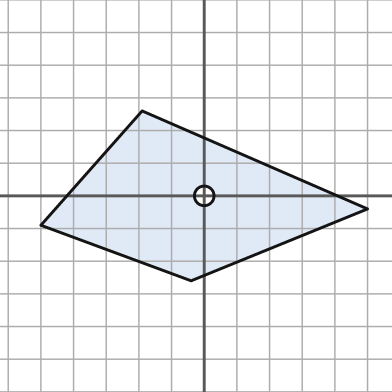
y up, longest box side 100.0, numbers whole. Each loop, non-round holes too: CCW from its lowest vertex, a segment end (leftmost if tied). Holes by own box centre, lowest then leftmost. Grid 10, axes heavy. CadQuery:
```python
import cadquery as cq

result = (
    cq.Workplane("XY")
    .moveTo(-4.0, -26.0)
    .lineTo(50.0, -4.0)
    .lineTo(-19.0, 26.0)
    .lineTo(-50.0, -9.0)
    .close()
    .moveTo(0.0, 0.0)
    .circle(3.0)
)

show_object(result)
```